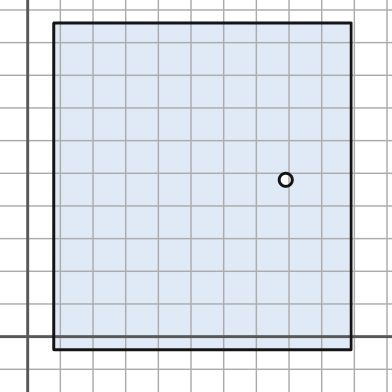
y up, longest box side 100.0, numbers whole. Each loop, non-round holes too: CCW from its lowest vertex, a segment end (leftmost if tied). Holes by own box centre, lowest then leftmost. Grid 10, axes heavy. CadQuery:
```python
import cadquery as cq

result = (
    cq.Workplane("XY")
    .moveTo(8.0, -4.0)
    .lineTo(99.0, -4.0)
    .lineTo(99.0, 96.0)
    .lineTo(8.0, 96.0)
    .close()
    .moveTo(79.0, 48.0)
    .circle(2.0)
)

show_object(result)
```